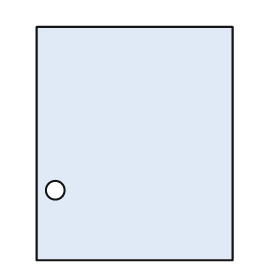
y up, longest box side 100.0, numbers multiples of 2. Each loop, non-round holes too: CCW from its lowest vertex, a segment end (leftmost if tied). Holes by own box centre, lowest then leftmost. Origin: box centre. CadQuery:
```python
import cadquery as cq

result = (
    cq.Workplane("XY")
    .moveTo(-42.0, -50.0)
    .lineTo(42.0, -50.0)
    .lineTo(42.0, 50.0)
    .lineTo(-42.0, 50.0)
    .close()
    .moveTo(-34.0, -20.0)
    .circle(4.0)
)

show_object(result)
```